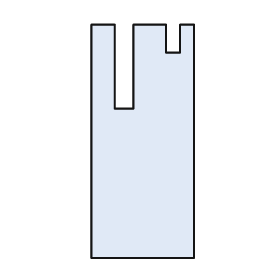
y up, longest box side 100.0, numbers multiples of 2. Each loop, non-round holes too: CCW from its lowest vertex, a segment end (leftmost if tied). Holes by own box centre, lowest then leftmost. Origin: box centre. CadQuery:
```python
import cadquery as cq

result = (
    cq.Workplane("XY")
    .moveTo(-22.0, -50.0)
    .lineTo(22.0, -50.0)
    .lineTo(22.0, 50.0)
    .lineTo(16.0, 50.0)
    .lineTo(16.0, 38.0)
    .lineTo(10.0, 38.0)
    .lineTo(10.0, 50.0)
    .lineTo(-4.0, 50.0)
    .lineTo(-4.0, 14.0)
    .lineTo(-12.0, 14.0)
    .lineTo(-12.0, 50.0)
    .lineTo(-22.0, 50.0)
    .close()
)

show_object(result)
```